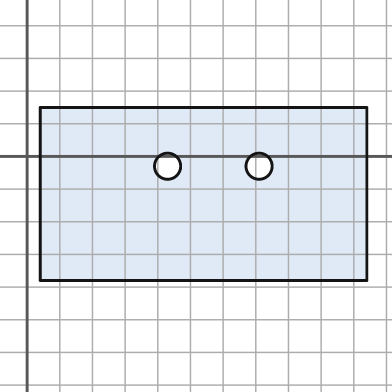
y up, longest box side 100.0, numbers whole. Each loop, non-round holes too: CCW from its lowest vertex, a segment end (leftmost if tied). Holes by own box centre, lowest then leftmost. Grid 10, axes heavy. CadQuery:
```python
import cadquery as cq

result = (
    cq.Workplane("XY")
    .moveTo(4.0, -38.0)
    .lineTo(104.0, -38.0)
    .lineTo(104.0, 15.0)
    .lineTo(4.0, 15.0)
    .close()
    .moveTo(43.0, -3.0)
    .circle(4.0)
    .moveTo(71.0, -3.0)
    .circle(4.0)
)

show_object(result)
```